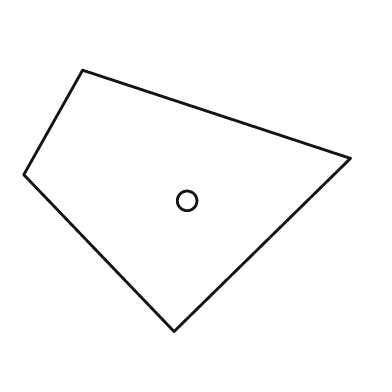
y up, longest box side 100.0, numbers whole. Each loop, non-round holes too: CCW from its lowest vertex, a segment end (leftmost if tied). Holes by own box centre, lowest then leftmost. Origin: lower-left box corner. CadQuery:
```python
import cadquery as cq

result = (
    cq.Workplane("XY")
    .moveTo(46.0, 0.0)
    .lineTo(100.0, 53.0)
    .lineTo(18.0, 80.0)
    .lineTo(0.0, 48.0)
    .close()
    .moveTo(50.0, 40.0)
    .circle(3.0)
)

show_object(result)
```